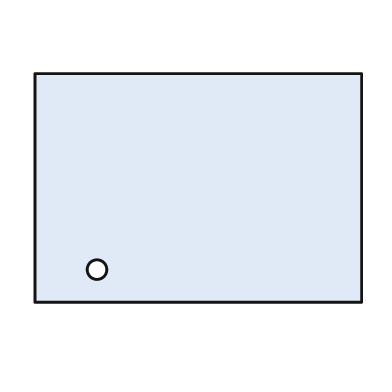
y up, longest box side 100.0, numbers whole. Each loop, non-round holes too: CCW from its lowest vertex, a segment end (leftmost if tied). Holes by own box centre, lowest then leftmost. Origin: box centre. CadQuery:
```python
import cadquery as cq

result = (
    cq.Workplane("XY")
    .moveTo(-50.0, -35.0)
    .lineTo(50.0, -35.0)
    .lineTo(50.0, 35.0)
    .lineTo(-50.0, 35.0)
    .close()
    .moveTo(-31.0, -25.0)
    .circle(3.0)
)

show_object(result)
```